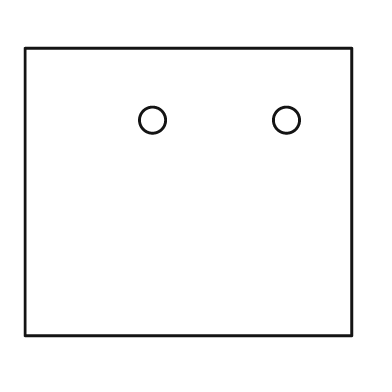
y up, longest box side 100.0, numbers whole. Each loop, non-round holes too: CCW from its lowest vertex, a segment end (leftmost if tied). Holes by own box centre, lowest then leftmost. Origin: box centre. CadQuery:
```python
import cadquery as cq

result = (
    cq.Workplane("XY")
    .moveTo(-50.0, -44.0)
    .lineTo(50.0, -44.0)
    .lineTo(50.0, 44.0)
    .lineTo(-50.0, 44.0)
    .close()
    .moveTo(-11.0, 22.0)
    .circle(4.0)
    .moveTo(30.0, 22.0)
    .circle(4.0)
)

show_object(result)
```